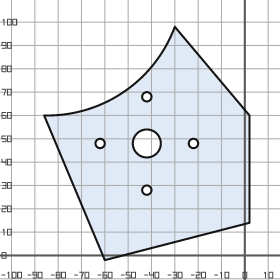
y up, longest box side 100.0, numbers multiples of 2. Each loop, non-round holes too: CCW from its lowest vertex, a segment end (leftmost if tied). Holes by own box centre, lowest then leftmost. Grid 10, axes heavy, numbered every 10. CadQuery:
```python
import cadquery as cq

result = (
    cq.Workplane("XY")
    .moveTo(-60.0, -2.0)
    .lineTo(2.0, 14.0)
    .lineTo(2.0, 60.0)
    .lineTo(-30.0, 98.0)
    .threePointArc((-52.0, 70.0), (-86.0, 60.0))
    .close()
    .moveTo(-42.0, 28.0)
    .circle(2.0)
    .moveTo(-62.0, 48.0)
    .circle(2.0)
    .moveTo(-42.0, 48.0)
    .circle(6.0)
    .moveTo(-22.0, 48.0)
    .circle(2.0)
    .moveTo(-42.0, 68.0)
    .circle(2.0)
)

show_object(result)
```